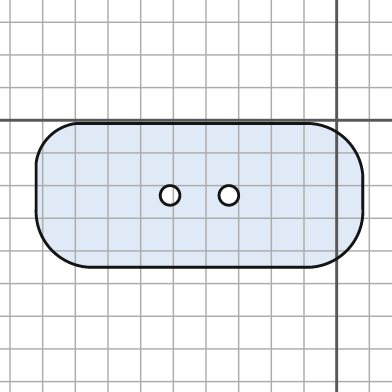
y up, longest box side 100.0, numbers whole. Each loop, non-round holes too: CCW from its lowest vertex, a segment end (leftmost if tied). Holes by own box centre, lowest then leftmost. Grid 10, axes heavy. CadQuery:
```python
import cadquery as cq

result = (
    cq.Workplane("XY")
    .moveTo(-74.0, -45.0)
    .lineTo(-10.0, -45.0)
    .threePointArc((3.0, -40.0), (8.0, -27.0))
    .lineTo(8.0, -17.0)
    .threePointArc((3.0, -6.0), (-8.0, -1.0))
    .lineTo(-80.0, -1.0)
    .threePointArc((-88.0, -5.0), (-92.0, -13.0))
    .lineTo(-92.0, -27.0)
    .threePointArc((-87.0, -40.0), (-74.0, -45.0))
    .close()
    .moveTo(-51.0, -23.0)
    .circle(3.0)
    .moveTo(-33.0, -23.0)
    .circle(3.0)
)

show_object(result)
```